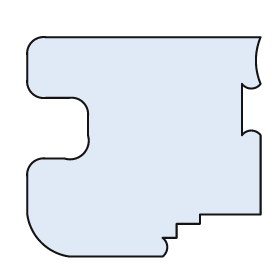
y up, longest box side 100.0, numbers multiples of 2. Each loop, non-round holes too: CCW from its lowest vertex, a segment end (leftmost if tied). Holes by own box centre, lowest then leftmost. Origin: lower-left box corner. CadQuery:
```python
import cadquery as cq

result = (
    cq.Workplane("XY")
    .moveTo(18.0, 0.0)
    .lineTo(58.0, 0.0)
    .threePointArc((60.0, 4.0), (58.0, 8.0))
    .lineTo(64.0, 8.0)
    .lineTo(64.0, 14.0)
    .lineTo(74.0, 14.0)
    .lineTo(74.0, 18.0)
    .lineTo(100.0, 18.0)
    .lineTo(100.0, 52.0)
    .threePointArc((96.0, 54.0), (92.0, 52.0))
    .lineTo(92.0, 74.0)
    .threePointArc((96.0, 72.0), (100.0, 74.0))
    .threePointArc((98.0, 84.0), (100.0, 94.0))
    .lineTo(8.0, 94.0)
    .threePointArc((2.0, 92.0), (0.0, 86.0))
    .lineTo(0.0, 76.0)
    .threePointArc((2.0, 70.0), (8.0, 68.0))
    .lineTo(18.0, 68.0)
    .threePointArc((24.0, 66.0), (26.0, 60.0))
    .lineTo(26.0, 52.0)
    .threePointArc((24.0, 44.0), (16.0, 42.0))
    .lineTo(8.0, 42.0)
    .threePointArc((2.0, 40.0), (0.0, 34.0))
    .lineTo(0.0, 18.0)
    .threePointArc((6.0, 6.0), (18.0, 0.0))
    .close()
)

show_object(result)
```